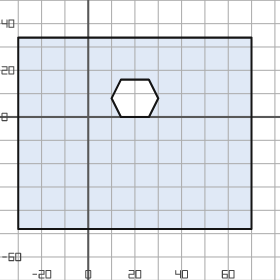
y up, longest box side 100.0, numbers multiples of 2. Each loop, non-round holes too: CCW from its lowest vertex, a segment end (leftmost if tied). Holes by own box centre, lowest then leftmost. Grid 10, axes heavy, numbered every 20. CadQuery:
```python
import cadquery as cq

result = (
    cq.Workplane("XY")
    .moveTo(-30.0, -48.0)
    .lineTo(70.0, -48.0)
    .lineTo(70.0, 34.0)
    .lineTo(-30.0, 34.0)
    .close()
    .moveTo(14.0, 0.0)
    .lineTo(26.0, 0.0)
    .lineTo(30.0, 8.0)
    .lineTo(26.0, 16.0)
    .lineTo(14.0, 16.0)
    .lineTo(10.0, 8.0)
    .close()
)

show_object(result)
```